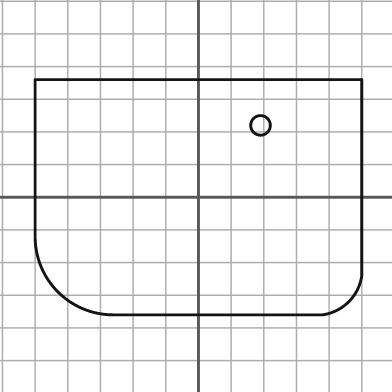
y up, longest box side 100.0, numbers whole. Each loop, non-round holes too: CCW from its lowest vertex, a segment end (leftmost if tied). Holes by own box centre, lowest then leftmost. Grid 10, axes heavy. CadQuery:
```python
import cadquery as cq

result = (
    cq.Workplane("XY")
    .moveTo(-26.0, -36.0)
    .lineTo(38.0, -36.0)
    .threePointArc((46.0, -32.0), (50.0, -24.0))
    .lineTo(50.0, 36.0)
    .lineTo(-50.0, 36.0)
    .lineTo(-50.0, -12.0)
    .threePointArc((-43.0, -29.0), (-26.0, -36.0))
    .close()
    .moveTo(19.0, 22.0)
    .circle(3.0)
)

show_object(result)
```